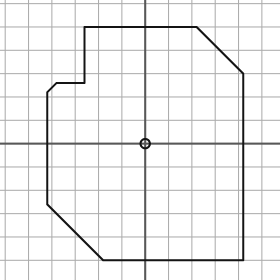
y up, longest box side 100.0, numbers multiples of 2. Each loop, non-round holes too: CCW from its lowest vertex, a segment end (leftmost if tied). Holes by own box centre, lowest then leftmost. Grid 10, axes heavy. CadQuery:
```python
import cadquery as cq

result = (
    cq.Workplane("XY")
    .moveTo(-18.0, -50.0)
    .lineTo(42.0, -50.0)
    .lineTo(42.0, 30.0)
    .lineTo(22.0, 50.0)
    .lineTo(-26.0, 50.0)
    .lineTo(-26.0, 26.0)
    .lineTo(-38.0, 26.0)
    .lineTo(-42.0, 22.0)
    .lineTo(-42.0, -26.0)
    .close()
    .moveTo(0.0, 0.0)
    .circle(2.0)
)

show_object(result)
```